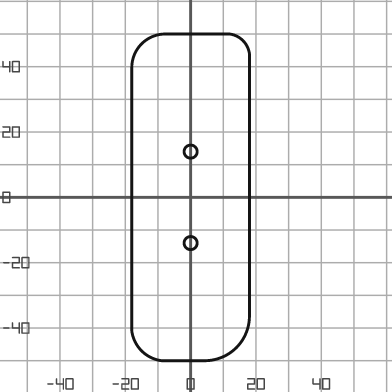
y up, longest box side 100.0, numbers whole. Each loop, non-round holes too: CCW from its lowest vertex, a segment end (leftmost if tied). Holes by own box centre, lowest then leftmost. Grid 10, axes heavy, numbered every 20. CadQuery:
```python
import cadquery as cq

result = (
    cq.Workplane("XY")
    .moveTo(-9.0, -50.0)
    .lineTo(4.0, -50.0)
    .threePointArc((14.0, -46.0), (18.0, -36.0))
    .lineTo(18.0, 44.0)
    .threePointArc((16.0, 48.0), (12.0, 50.0))
    .lineTo(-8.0, 50.0)
    .threePointArc((-15.0, 47.0), (-18.0, 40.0))
    .lineTo(-18.0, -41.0)
    .threePointArc((-15.0, -47.0), (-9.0, -50.0))
    .close()
    .moveTo(0.0, -14.0)
    .circle(2.0)
    .moveTo(0.0, 14.0)
    .circle(2.0)
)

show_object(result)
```